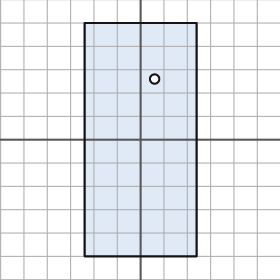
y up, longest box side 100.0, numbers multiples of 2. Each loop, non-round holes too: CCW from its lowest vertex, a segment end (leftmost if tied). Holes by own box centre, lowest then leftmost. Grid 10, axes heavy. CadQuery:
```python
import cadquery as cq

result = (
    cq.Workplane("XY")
    .moveTo(-24.0, -50.0)
    .lineTo(24.0, -50.0)
    .lineTo(24.0, 50.0)
    .lineTo(-24.0, 50.0)
    .close()
    .moveTo(6.0, 26.0)
    .circle(2.0)
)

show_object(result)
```